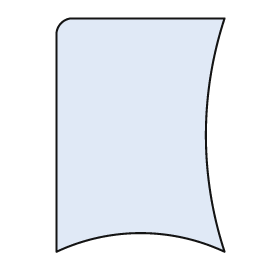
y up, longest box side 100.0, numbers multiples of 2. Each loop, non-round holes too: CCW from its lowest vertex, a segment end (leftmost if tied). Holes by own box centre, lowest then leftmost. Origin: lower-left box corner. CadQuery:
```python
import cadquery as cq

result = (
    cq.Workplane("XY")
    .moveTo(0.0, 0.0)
    .threePointArc((36.0, 8.0), (72.0, 0.0))
    .threePointArc((64.0, 50.0), (72.0, 100.0))
    .lineTo(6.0, 100.0)
    .threePointArc((2.0, 98.0), (0.0, 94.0))
    .close()
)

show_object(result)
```